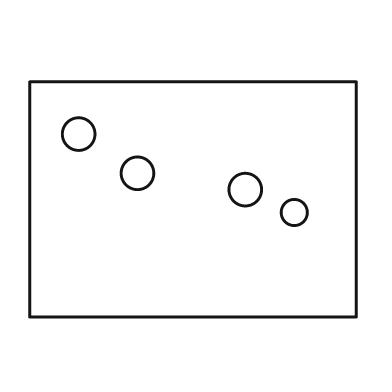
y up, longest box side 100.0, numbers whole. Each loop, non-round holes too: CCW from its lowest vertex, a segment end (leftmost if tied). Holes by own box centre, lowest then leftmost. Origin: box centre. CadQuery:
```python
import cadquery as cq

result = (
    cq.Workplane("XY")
    .moveTo(-50.0, -36.0)
    .lineTo(50.0, -36.0)
    .lineTo(50.0, 36.0)
    .lineTo(-50.0, 36.0)
    .close()
    .moveTo(31.0, -4.0)
    .circle(4.0)
    .moveTo(16.0, 3.0)
    .circle(5.0)
    .moveTo(-17.0, 8.0)
    .circle(5.0)
    .moveTo(-35.0, 20.0)
    .circle(5.0)
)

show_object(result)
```